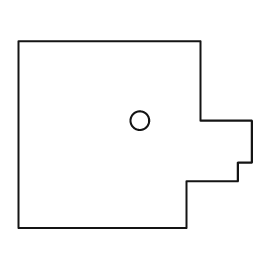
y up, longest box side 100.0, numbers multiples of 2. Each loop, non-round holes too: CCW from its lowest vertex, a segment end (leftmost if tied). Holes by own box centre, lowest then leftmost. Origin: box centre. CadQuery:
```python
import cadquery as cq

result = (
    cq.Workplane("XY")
    .moveTo(-50.0, -40.0)
    .lineTo(22.0, -40.0)
    .lineTo(22.0, -20.0)
    .lineTo(44.0, -20.0)
    .lineTo(44.0, -12.0)
    .lineTo(50.0, -12.0)
    .lineTo(50.0, 6.0)
    .lineTo(28.0, 6.0)
    .lineTo(28.0, 40.0)
    .lineTo(-50.0, 40.0)
    .close()
    .moveTo(2.0, 6.0)
    .circle(4.0)
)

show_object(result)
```